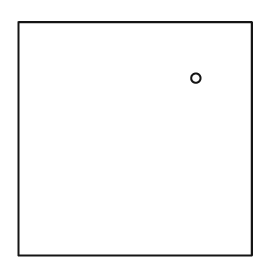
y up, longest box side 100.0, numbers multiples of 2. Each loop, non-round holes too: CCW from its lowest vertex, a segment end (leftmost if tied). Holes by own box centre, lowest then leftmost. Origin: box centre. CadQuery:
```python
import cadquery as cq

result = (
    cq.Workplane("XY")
    .moveTo(-50.0, -50.0)
    .lineTo(50.0, -50.0)
    .lineTo(50.0, 50.0)
    .lineTo(-50.0, 50.0)
    .close()
    .moveTo(26.0, 26.0)
    .circle(2.0)
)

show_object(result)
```